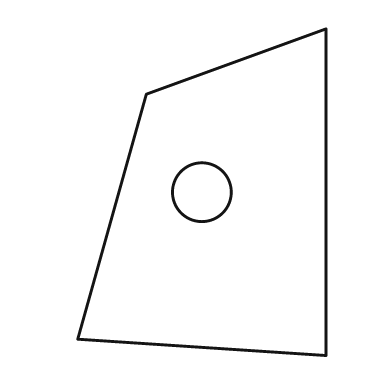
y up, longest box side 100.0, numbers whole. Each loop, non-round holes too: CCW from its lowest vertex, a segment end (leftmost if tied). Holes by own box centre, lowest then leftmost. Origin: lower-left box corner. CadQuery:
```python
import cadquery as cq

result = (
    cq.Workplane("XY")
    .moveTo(76.0, 0.0)
    .lineTo(76.0, 100.0)
    .lineTo(21.0, 80.0)
    .lineTo(0.0, 5.0)
    .close()
    .moveTo(38.0, 50.0)
    .circle(9.0)
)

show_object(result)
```